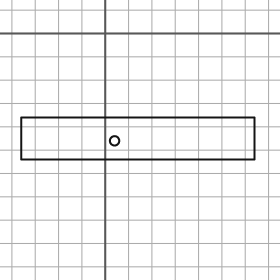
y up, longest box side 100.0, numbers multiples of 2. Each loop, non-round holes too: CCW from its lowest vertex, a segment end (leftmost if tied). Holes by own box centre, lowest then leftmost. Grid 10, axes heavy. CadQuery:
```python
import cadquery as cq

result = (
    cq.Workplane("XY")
    .moveTo(-36.0, -54.0)
    .lineTo(64.0, -54.0)
    .lineTo(64.0, -36.0)
    .lineTo(-36.0, -36.0)
    .close()
    .moveTo(4.0, -46.0)
    .circle(2.0)
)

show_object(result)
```